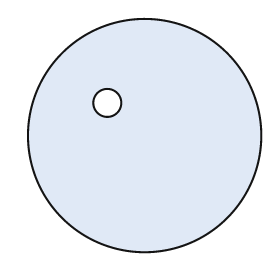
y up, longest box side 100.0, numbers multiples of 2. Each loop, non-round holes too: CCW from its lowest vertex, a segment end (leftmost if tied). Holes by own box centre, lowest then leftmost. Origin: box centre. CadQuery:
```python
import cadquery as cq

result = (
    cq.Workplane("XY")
    .moveTo(0.0, 0.0)
    .circle(50.0)
    .moveTo(-16.0, 14.0)
    .circle(6.0)
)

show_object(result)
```